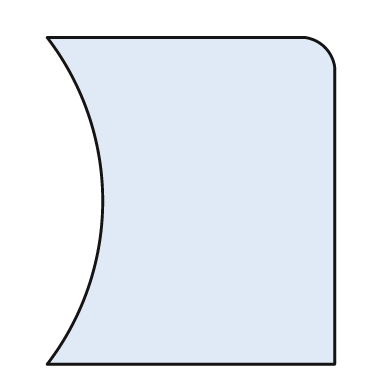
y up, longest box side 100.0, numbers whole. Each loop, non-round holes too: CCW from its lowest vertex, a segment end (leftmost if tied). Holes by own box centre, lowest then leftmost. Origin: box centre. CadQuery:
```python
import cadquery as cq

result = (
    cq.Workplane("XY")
    .moveTo(-44.0, -50.0)
    .lineTo(44.0, -50.0)
    .lineTo(44.0, 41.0)
    .threePointArc((41.0, 47.0), (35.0, 50.0))
    .lineTo(-44.0, 50.0)
    .threePointArc((-27.0, 0.0), (-44.0, -50.0))
    .close()
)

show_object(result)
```